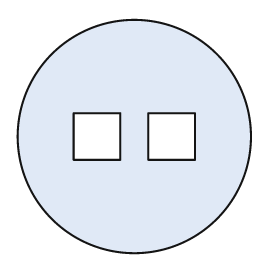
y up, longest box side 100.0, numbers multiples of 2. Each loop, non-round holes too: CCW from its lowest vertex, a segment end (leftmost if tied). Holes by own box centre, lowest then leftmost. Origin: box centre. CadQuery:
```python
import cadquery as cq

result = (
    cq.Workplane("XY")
    .moveTo(0.0, 0.0)
    .circle(50.0)
    .moveTo(-26.0, -10.0)
    .lineTo(-6.0, -10.0)
    .lineTo(-6.0, 10.0)
    .lineTo(-26.0, 10.0)
    .close()
    .moveTo(6.0, -10.0)
    .lineTo(26.0, -10.0)
    .lineTo(26.0, 10.0)
    .lineTo(6.0, 10.0)
    .close()
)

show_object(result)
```